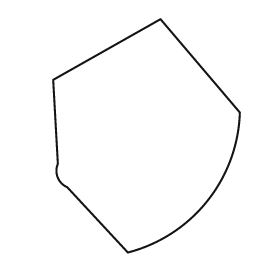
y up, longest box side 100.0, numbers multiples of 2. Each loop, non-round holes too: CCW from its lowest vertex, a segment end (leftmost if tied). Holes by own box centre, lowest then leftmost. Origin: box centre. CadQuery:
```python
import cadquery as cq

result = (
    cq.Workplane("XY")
    .moveTo(-8.0, -50.0)
    .threePointArc((26.0, -28.0), (40.0, 10.0))
    .lineTo(6.0, 50.0)
    .lineTo(-40.0, 24.0)
    .lineTo(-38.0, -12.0)
    .threePointArc((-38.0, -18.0), (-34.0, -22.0))
    .close()
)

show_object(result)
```